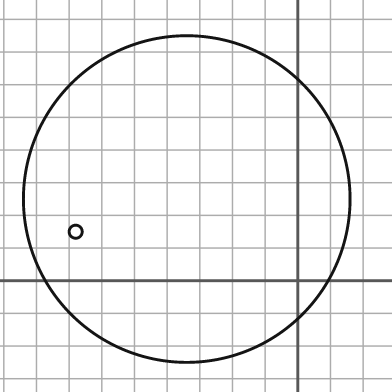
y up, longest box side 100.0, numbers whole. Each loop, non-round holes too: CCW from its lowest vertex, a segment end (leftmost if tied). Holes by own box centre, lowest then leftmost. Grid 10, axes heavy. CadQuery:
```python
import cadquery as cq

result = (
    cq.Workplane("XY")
    .moveTo(-34.0, 25.0)
    .circle(50.0)
    .moveTo(-68.0, 15.0)
    .circle(2.0)
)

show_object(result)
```